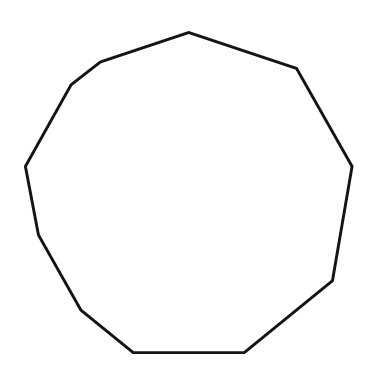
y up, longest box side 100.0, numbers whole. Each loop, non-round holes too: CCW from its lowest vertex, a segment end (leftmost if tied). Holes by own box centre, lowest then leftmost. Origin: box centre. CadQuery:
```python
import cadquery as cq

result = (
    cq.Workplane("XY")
    .moveTo(-17.0, -49.0)
    .lineTo(17.0, -49.0)
    .lineTo(44.0, -27.0)
    .lineTo(50.0, 8.0)
    .lineTo(33.0, 38.0)
    .lineTo(0.0, 49.0)
    .lineTo(-27.0, 40.0)
    .lineTo(-36.0, 33.0)
    .lineTo(-50.0, 8.0)
    .lineTo(-46.0, -13.0)
    .lineTo(-33.0, -36.0)
    .close()
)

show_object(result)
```